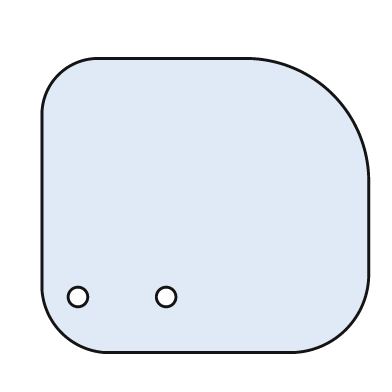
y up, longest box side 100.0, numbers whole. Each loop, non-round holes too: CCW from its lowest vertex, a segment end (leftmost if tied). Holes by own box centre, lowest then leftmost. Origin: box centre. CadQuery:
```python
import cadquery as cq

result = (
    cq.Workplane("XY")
    .moveTo(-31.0, -45.0)
    .lineTo(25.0, -45.0)
    .threePointArc((43.0, -38.0), (50.0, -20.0))
    .lineTo(50.0, 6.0)
    .threePointArc((39.0, 34.0), (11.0, 45.0))
    .lineTo(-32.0, 45.0)
    .threePointArc((-45.0, 40.0), (-50.0, 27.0))
    .lineTo(-50.0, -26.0)
    .threePointArc((-44.0, -39.0), (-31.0, -45.0))
    .close()
    .moveTo(-39.0, -28.0)
    .circle(3.0)
    .moveTo(-12.0, -28.0)
    .circle(3.0)
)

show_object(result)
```